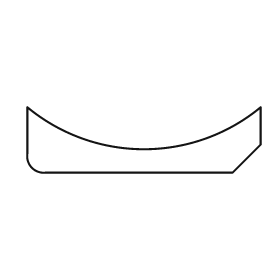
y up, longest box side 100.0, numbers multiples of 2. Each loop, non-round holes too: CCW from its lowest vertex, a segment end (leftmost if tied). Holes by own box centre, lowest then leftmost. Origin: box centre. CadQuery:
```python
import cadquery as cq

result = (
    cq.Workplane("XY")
    .moveTo(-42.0, -14.0)
    .lineTo(38.0, -14.0)
    .lineTo(50.0, -2.0)
    .lineTo(50.0, 14.0)
    .threePointArc((0.0, -4.0), (-50.0, 14.0))
    .lineTo(-50.0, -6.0)
    .threePointArc((-48.0, -12.0), (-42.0, -14.0))
    .close()
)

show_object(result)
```